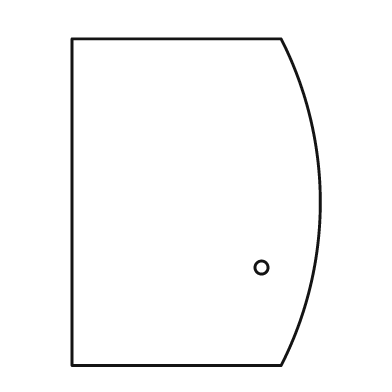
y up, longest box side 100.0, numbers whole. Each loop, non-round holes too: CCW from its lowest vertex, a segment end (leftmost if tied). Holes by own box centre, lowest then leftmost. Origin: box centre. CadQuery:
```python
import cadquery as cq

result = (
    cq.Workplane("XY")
    .moveTo(-38.0, -50.0)
    .lineTo(26.0, -50.0)
    .threePointArc((38.0, 0.0), (26.0, 50.0))
    .lineTo(-38.0, 50.0)
    .close()
    .moveTo(20.0, -20.0)
    .circle(2.0)
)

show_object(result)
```